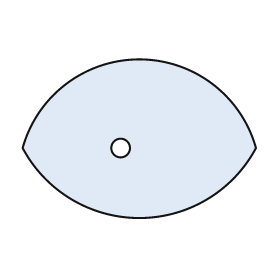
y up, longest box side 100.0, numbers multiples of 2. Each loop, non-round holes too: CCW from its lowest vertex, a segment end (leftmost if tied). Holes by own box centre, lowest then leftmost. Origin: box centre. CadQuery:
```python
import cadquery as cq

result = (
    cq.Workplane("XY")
    .moveTo(-50.0, -4.0)
    .threePointArc((0.0, -34.0), (50.0, -4.0))
    .threePointArc((0.0, 34.0), (-50.0, -4.0))
    .close()
    .moveTo(-8.0, -4.0)
    .circle(4.0)
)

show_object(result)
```